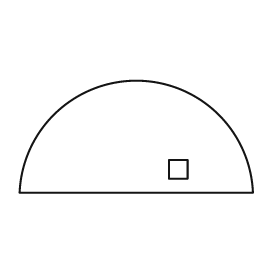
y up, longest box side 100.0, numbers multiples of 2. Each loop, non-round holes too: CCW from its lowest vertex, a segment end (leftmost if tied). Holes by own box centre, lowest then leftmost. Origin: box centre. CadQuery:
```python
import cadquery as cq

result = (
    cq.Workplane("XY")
    .moveTo(-50.0, -24.0)
    .lineTo(50.0, -24.0)
    .threePointArc((0.0, 24.0), (-50.0, -24.0))
    .close()
    .moveTo(14.0, -18.0)
    .lineTo(22.0, -18.0)
    .lineTo(22.0, -10.0)
    .lineTo(14.0, -10.0)
    .close()
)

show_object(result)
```